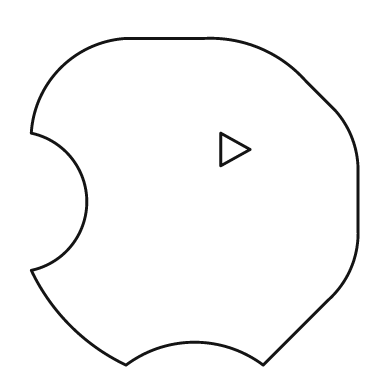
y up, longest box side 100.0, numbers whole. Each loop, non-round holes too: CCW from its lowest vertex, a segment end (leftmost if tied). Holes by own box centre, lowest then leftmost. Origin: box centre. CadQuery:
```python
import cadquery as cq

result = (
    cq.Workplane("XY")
    .moveTo(-21.0, -50.0)
    .threePointArc((0.0, -43.0), (21.0, -50.0))
    .lineTo(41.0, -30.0)
    .threePointArc((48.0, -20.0), (50.0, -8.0))
    .lineTo(50.0, 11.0)
    .threePointArc((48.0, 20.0), (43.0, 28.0))
    .lineTo(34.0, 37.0)
    .threePointArc((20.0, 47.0), (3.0, 50.0))
    .lineTo(-21.0, 50.0)
    .threePointArc((-41.0, 41.0), (-50.0, 21.0))
    .threePointArc((-33.0, 0.0), (-50.0, -21.0))
    .threePointArc((-38.0, -38.0), (-21.0, -50.0))
    .close()
    .moveTo(8.0, 11.0)
    .lineTo(17.0, 16.0)
    .lineTo(8.0, 21.0)
    .close()
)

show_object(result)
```